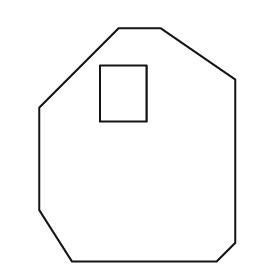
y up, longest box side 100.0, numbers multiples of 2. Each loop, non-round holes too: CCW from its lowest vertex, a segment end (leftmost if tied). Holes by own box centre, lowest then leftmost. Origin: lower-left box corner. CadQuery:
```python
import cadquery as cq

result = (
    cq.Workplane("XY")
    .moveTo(14.0, 0.0)
    .lineTo(76.0, 0.0)
    .lineTo(84.0, 8.0)
    .lineTo(84.0, 78.0)
    .lineTo(52.0, 100.0)
    .lineTo(34.0, 100.0)
    .lineTo(0.0, 66.0)
    .lineTo(0.0, 22.0)
    .close()
    .moveTo(26.0, 60.0)
    .lineTo(46.0, 60.0)
    .lineTo(46.0, 84.0)
    .lineTo(26.0, 84.0)
    .close()
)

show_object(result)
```